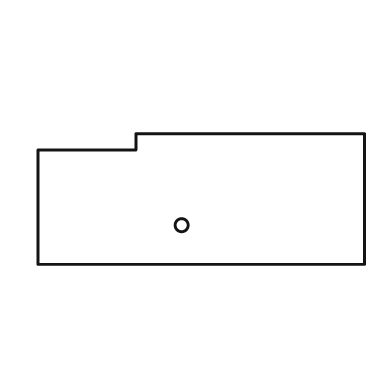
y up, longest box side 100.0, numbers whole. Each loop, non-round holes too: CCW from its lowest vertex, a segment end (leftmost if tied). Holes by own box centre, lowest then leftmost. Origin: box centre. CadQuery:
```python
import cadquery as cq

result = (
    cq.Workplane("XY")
    .moveTo(-50.0, -20.0)
    .lineTo(50.0, -20.0)
    .lineTo(50.0, 20.0)
    .lineTo(-20.0, 20.0)
    .lineTo(-20.0, 15.0)
    .lineTo(-50.0, 15.0)
    .close()
    .moveTo(-6.0, -8.0)
    .circle(2.0)
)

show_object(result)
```